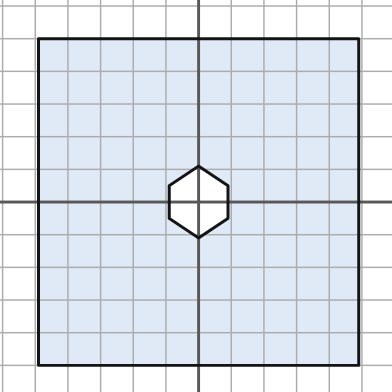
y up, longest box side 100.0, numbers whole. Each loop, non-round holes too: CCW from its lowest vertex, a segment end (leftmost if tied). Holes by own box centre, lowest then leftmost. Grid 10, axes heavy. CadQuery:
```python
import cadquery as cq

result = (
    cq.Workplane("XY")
    .moveTo(-49.0, -50.0)
    .lineTo(49.0, -50.0)
    .lineTo(49.0, 50.0)
    .lineTo(-49.0, 50.0)
    .close()
    .moveTo(0.0, -11.0)
    .lineTo(9.0, -5.0)
    .lineTo(9.0, 5.0)
    .lineTo(0.0, 11.0)
    .lineTo(-9.0, 5.0)
    .lineTo(-9.0, -5.0)
    .close()
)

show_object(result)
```